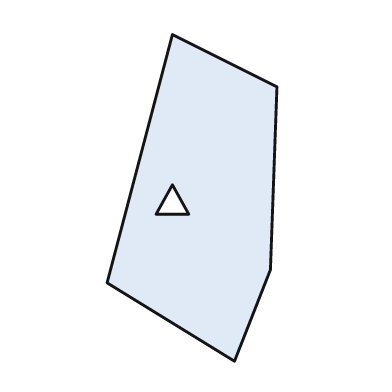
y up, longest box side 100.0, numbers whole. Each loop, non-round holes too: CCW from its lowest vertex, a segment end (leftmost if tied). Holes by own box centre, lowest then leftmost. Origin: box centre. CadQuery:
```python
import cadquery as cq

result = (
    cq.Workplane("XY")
    .moveTo(13.0, -50.0)
    .lineTo(24.0, -22.0)
    .lineTo(26.0, 34.0)
    .lineTo(-6.0, 50.0)
    .lineTo(-26.0, -26.0)
    .close()
    .moveTo(-11.0, -5.0)
    .lineTo(-1.0, -5.0)
    .lineTo(-6.0, 4.0)
    .close()
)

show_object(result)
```